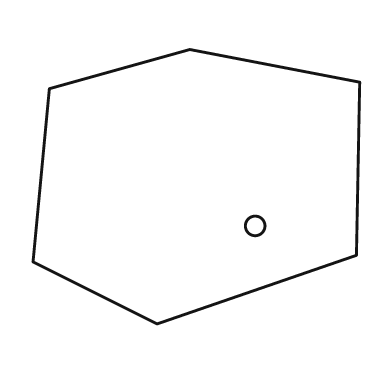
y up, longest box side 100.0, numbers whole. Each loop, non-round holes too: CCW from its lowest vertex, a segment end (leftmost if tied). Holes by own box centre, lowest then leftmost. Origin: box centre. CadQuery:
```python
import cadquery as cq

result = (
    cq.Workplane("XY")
    .moveTo(-12.0, -42.0)
    .lineTo(49.0, -21.0)
    .lineTo(50.0, 32.0)
    .lineTo(-2.0, 42.0)
    .lineTo(-45.0, 30.0)
    .lineTo(-50.0, -23.0)
    .close()
    .moveTo(18.0, -12.0)
    .circle(3.0)
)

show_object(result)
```